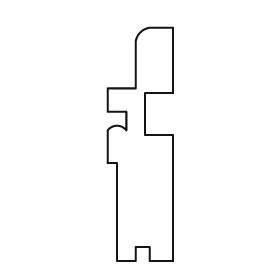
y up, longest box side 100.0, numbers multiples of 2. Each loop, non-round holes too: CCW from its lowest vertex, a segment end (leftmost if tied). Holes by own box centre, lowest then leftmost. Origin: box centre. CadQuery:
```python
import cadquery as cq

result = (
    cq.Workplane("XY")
    .moveTo(-10.0, -50.0)
    .lineTo(-2.0, -50.0)
    .lineTo(-2.0, -44.0)
    .lineTo(4.0, -44.0)
    .lineTo(4.0, -50.0)
    .lineTo(14.0, -50.0)
    .lineTo(14.0, 4.0)
    .lineTo(2.0, 4.0)
    .lineTo(2.0, 22.0)
    .lineTo(14.0, 22.0)
    .lineTo(14.0, 50.0)
    .lineTo(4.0, 50.0)
    .threePointArc((0.0, 48.0), (-2.0, 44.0))
    .lineTo(-2.0, 24.0)
    .lineTo(-14.0, 24.0)
    .lineTo(-14.0, 14.0)
    .lineTo(-6.0, 14.0)
    .lineTo(-6.0, 6.0)
    .threePointArc((-10.0, 8.0), (-14.0, 6.0))
    .lineTo(-14.0, -8.0)
    .lineTo(-10.0, -8.0)
    .close()
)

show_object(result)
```